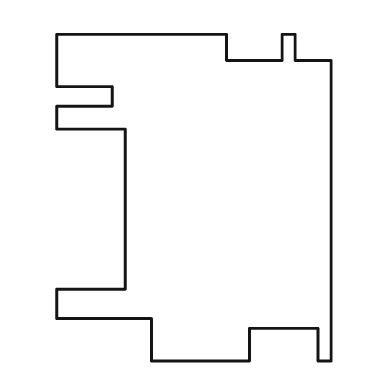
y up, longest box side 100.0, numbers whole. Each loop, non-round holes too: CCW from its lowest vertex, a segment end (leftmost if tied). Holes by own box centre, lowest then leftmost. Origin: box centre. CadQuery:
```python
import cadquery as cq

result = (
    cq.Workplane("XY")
    .moveTo(-13.0, -50.0)
    .lineTo(17.0, -50.0)
    .lineTo(17.0, -40.0)
    .lineTo(38.0, -40.0)
    .lineTo(38.0, -50.0)
    .lineTo(42.0, -50.0)
    .lineTo(42.0, 42.0)
    .lineTo(31.0, 42.0)
    .lineTo(31.0, 50.0)
    .lineTo(27.0, 50.0)
    .lineTo(27.0, 42.0)
    .lineTo(10.0, 42.0)
    .lineTo(10.0, 50.0)
    .lineTo(-42.0, 50.0)
    .lineTo(-42.0, 34.0)
    .lineTo(-25.0, 34.0)
    .lineTo(-25.0, 28.0)
    .lineTo(-42.0, 28.0)
    .lineTo(-42.0, 21.0)
    .lineTo(-21.0, 21.0)
    .lineTo(-21.0, -28.0)
    .lineTo(-42.0, -28.0)
    .lineTo(-42.0, -37.0)
    .lineTo(-13.0, -37.0)
    .close()
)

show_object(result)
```